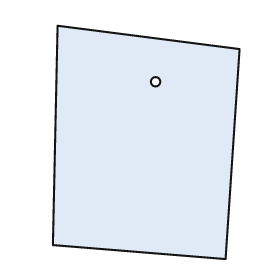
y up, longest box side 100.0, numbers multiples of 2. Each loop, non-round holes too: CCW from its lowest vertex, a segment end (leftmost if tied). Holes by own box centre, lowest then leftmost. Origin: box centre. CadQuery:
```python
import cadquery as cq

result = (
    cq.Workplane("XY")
    .moveTo(34.0, -50.0)
    .lineTo(40.0, 40.0)
    .lineTo(-38.0, 50.0)
    .lineTo(-40.0, -44.0)
    .close()
    .moveTo(4.0, 26.0)
    .circle(2.0)
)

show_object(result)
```